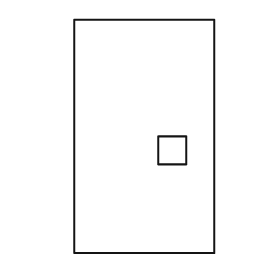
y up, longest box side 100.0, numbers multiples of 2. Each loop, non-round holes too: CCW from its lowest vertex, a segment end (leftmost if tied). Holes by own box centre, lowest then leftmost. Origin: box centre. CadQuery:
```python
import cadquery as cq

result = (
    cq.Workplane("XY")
    .moveTo(-30.0, -50.0)
    .lineTo(30.0, -50.0)
    .lineTo(30.0, 50.0)
    .lineTo(-30.0, 50.0)
    .close()
    .moveTo(6.0, -12.0)
    .lineTo(18.0, -12.0)
    .lineTo(18.0, 0.0)
    .lineTo(6.0, 0.0)
    .close()
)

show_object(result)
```